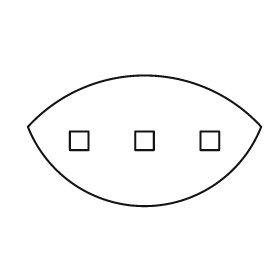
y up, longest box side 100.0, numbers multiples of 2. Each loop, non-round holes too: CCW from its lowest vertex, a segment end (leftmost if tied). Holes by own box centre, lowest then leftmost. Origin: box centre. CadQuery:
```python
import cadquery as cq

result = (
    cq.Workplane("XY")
    .moveTo(-50.0, 6.0)
    .threePointArc((0.0, -28.0), (50.0, 6.0))
    .threePointArc((0.0, 28.0), (-50.0, 6.0))
    .close()
    .moveTo(-32.0, -4.0)
    .lineTo(-24.0, -4.0)
    .lineTo(-24.0, 4.0)
    .lineTo(-32.0, 4.0)
    .close()
    .moveTo(-4.0, -4.0)
    .lineTo(4.0, -4.0)
    .lineTo(4.0, 4.0)
    .lineTo(-4.0, 4.0)
    .close()
    .moveTo(24.0, -4.0)
    .lineTo(32.0, -4.0)
    .lineTo(32.0, 4.0)
    .lineTo(24.0, 4.0)
    .close()
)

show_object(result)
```